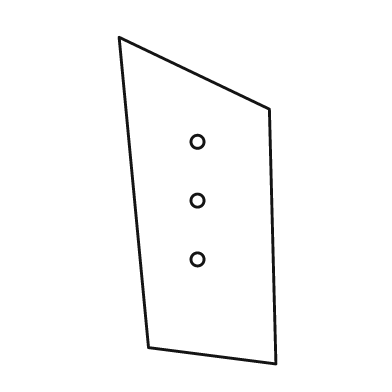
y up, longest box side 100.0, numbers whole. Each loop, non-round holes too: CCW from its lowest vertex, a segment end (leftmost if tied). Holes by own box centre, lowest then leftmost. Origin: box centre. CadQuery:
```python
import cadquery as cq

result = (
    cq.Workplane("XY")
    .moveTo(24.0, -50.0)
    .lineTo(22.0, 28.0)
    .lineTo(-24.0, 50.0)
    .lineTo(-15.0, -45.0)
    .close()
    .moveTo(0.0, -18.0)
    .circle(2.0)
    .moveTo(0.0, 0.0)
    .circle(2.0)
    .moveTo(0.0, 18.0)
    .circle(2.0)
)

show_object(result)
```